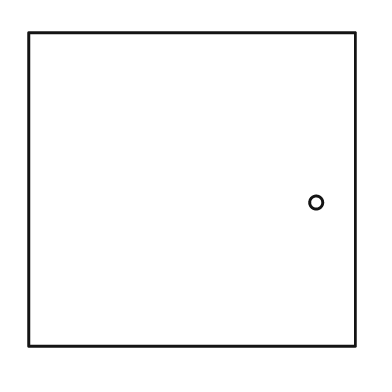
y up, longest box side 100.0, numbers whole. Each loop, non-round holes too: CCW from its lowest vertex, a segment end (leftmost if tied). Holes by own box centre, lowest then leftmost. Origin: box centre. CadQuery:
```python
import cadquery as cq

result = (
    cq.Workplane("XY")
    .moveTo(-50.0, -48.0)
    .lineTo(50.0, -48.0)
    .lineTo(50.0, 48.0)
    .lineTo(-50.0, 48.0)
    .close()
    .moveTo(38.0, -4.0)
    .circle(2.0)
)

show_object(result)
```